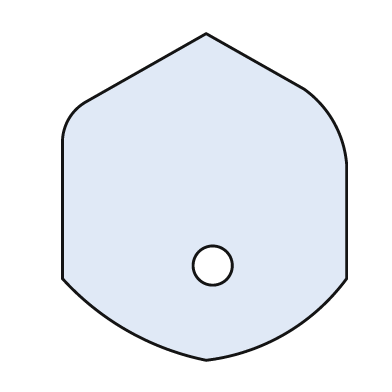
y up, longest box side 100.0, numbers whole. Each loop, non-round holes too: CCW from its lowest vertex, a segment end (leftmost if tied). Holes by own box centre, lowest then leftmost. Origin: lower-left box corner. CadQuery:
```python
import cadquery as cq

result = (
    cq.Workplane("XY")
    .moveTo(44.0, 0.0)
    .threePointArc((68.0, 8.0), (87.0, 25.0))
    .lineTo(87.0, 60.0)
    .threePointArc((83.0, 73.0), (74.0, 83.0))
    .lineTo(44.0, 100.0)
    .lineTo(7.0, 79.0)
    .threePointArc((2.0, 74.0), (0.0, 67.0))
    .lineTo(0.0, 25.0)
    .threePointArc((20.0, 9.0), (44.0, 0.0))
    .close()
    .moveTo(46.0, 29.0)
    .circle(6.0)
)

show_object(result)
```